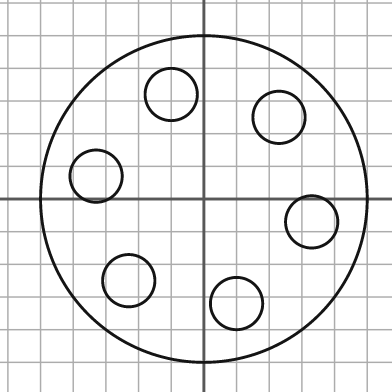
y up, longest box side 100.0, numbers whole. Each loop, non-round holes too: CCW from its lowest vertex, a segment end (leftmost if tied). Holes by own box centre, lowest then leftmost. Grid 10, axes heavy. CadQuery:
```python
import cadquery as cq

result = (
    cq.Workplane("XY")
    .moveTo(0.0, 0.0)
    .circle(50.0)
    .moveTo(10.0, -32.0)
    .circle(8.0)
    .moveTo(-23.0, -25.0)
    .circle(8.0)
    .moveTo(33.0, -7.0)
    .circle(8.0)
    .moveTo(-33.0, 7.0)
    .circle(8.0)
    .moveTo(23.0, 25.0)
    .circle(8.0)
    .moveTo(-10.0, 32.0)
    .circle(8.0)
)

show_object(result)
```